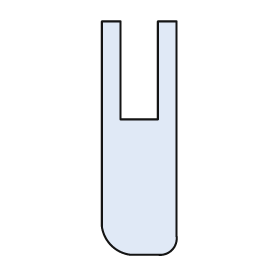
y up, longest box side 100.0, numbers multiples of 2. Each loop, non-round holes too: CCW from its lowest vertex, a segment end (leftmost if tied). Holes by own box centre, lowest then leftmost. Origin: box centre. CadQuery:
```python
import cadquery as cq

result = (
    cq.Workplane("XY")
    .moveTo(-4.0, -50.0)
    .lineTo(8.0, -50.0)
    .threePointArc((14.0, -48.0), (16.0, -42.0))
    .lineTo(16.0, 50.0)
    .lineTo(8.0, 50.0)
    .lineTo(8.0, 8.0)
    .lineTo(-8.0, 8.0)
    .lineTo(-8.0, 50.0)
    .lineTo(-16.0, 50.0)
    .lineTo(-16.0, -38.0)
    .threePointArc((-12.0, -46.0), (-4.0, -50.0))
    .close()
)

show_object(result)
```